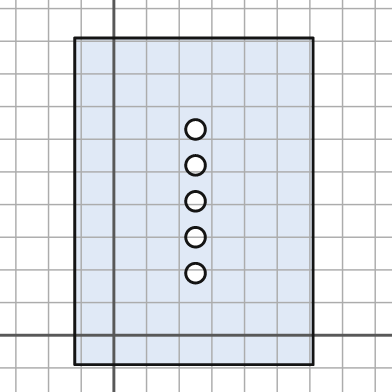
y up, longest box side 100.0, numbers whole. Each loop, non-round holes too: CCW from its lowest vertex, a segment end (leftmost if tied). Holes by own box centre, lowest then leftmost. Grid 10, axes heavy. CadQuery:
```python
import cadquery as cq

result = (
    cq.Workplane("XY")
    .moveTo(-12.0, -9.0)
    .lineTo(61.0, -9.0)
    .lineTo(61.0, 91.0)
    .lineTo(-12.0, 91.0)
    .close()
    .moveTo(25.0, 19.0)
    .circle(3.0)
    .moveTo(25.0, 30.0)
    .circle(3.0)
    .moveTo(25.0, 41.0)
    .circle(3.0)
    .moveTo(25.0, 52.0)
    .circle(3.0)
    .moveTo(25.0, 63.0)
    .circle(3.0)
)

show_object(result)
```